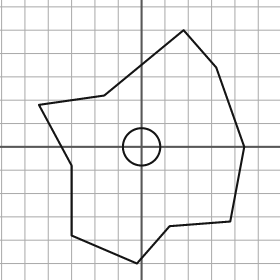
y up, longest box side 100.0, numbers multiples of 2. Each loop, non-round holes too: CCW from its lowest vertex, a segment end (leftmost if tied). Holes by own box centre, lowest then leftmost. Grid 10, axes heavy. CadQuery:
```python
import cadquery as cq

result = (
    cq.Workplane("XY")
    .moveTo(-2.0, -50.0)
    .lineTo(12.0, -34.0)
    .lineTo(38.0, -32.0)
    .lineTo(44.0, 0.0)
    .lineTo(32.0, 34.0)
    .lineTo(18.0, 50.0)
    .lineTo(-16.0, 22.0)
    .lineTo(-44.0, 18.0)
    .lineTo(-30.0, -8.0)
    .lineTo(-30.0, -38.0)
    .close()
    .moveTo(0.0, 0.0)
    .circle(8.0)
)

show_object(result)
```